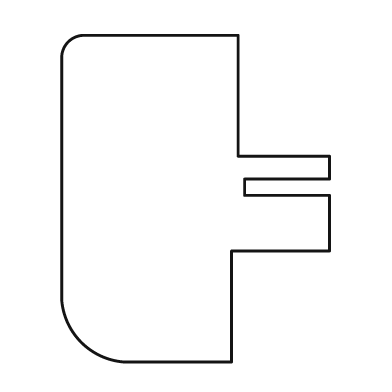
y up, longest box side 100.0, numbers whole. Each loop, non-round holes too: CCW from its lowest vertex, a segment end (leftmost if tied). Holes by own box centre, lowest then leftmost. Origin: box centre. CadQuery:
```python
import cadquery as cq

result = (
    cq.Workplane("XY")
    .moveTo(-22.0, -50.0)
    .lineTo(11.0, -50.0)
    .lineTo(11.0, -16.0)
    .lineTo(41.0, -16.0)
    .lineTo(41.0, 1.0)
    .lineTo(15.0, 1.0)
    .lineTo(15.0, 6.0)
    .lineTo(41.0, 6.0)
    .lineTo(41.0, 13.0)
    .lineTo(13.0, 13.0)
    .lineTo(13.0, 50.0)
    .lineTo(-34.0, 50.0)
    .threePointArc((-39.0, 48.0), (-41.0, 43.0))
    .lineTo(-41.0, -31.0)
    .threePointArc((-35.0, -44.0), (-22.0, -50.0))
    .close()
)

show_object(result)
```